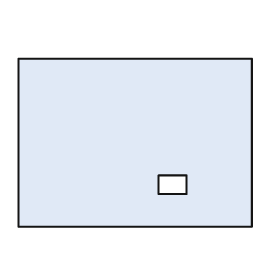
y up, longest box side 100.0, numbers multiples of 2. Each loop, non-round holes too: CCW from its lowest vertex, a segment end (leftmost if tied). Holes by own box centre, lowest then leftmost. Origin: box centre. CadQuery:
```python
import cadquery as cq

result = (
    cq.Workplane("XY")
    .moveTo(-50.0, -36.0)
    .lineTo(50.0, -36.0)
    .lineTo(50.0, 36.0)
    .lineTo(-50.0, 36.0)
    .close()
    .moveTo(10.0, -22.0)
    .lineTo(22.0, -22.0)
    .lineTo(22.0, -14.0)
    .lineTo(10.0, -14.0)
    .close()
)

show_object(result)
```